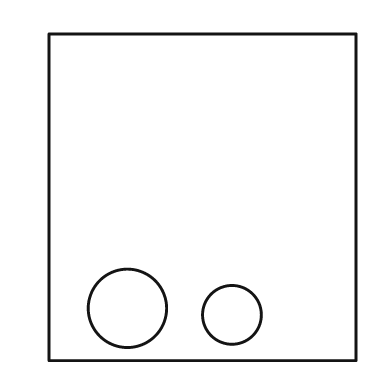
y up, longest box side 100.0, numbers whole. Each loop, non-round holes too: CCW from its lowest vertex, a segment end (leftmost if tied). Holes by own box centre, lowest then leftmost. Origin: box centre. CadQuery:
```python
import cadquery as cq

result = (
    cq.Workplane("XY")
    .moveTo(-47.0, -50.0)
    .lineTo(47.0, -50.0)
    .lineTo(47.0, 50.0)
    .lineTo(-47.0, 50.0)
    .close()
    .moveTo(9.0, -36.0)
    .circle(9.0)
    .moveTo(-23.0, -34.0)
    .circle(12.0)
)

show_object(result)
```